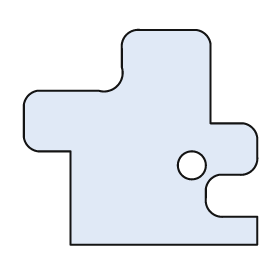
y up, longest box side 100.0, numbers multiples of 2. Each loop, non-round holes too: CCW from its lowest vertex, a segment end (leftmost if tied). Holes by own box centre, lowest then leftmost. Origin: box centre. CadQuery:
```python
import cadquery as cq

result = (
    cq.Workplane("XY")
    .moveTo(-30.0, -46.0)
    .lineTo(50.0, -46.0)
    .lineTo(50.0, -34.0)
    .lineTo(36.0, -34.0)
    .threePointArc((30.0, -32.0), (28.0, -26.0))
    .lineTo(28.0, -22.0)
    .threePointArc((30.0, -18.0), (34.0, -16.0))
    .lineTo(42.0, -16.0)
    .threePointArc((48.0, -14.0), (50.0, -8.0))
    .lineTo(50.0, 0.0)
    .threePointArc((48.0, 4.0), (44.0, 6.0))
    .lineTo(30.0, 6.0)
    .lineTo(30.0, 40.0)
    .threePointArc((28.0, 44.0), (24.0, 46.0))
    .lineTo(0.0, 46.0)
    .threePointArc((-6.0, 44.0), (-8.0, 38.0))
    .lineTo(-8.0, 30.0)
    .threePointArc((-10.0, 22.0), (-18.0, 20.0))
    .lineTo(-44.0, 20.0)
    .threePointArc((-48.0, 18.0), (-50.0, 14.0))
    .lineTo(-50.0, 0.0)
    .threePointArc((-48.0, -4.0), (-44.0, -6.0))
    .lineTo(-30.0, -6.0)
    .close()
    .moveTo(22.0, -12.0)
    .circle(6.0)
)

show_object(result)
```